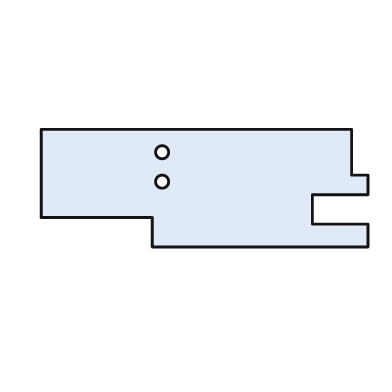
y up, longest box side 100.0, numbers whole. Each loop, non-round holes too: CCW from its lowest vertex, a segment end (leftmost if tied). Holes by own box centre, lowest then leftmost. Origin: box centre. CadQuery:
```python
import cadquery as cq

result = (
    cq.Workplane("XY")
    .moveTo(-16.0, -18.0)
    .lineTo(50.0, -18.0)
    .lineTo(50.0, -11.0)
    .lineTo(33.0, -11.0)
    .lineTo(33.0, -2.0)
    .lineTo(50.0, -2.0)
    .lineTo(50.0, 4.0)
    .lineTo(45.0, 4.0)
    .lineTo(45.0, 18.0)
    .lineTo(-50.0, 18.0)
    .lineTo(-50.0, -9.0)
    .lineTo(-16.0, -9.0)
    .close()
    .moveTo(-13.0, 2.0)
    .circle(2.0)
    .moveTo(-13.0, 11.0)
    .circle(2.0)
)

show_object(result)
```